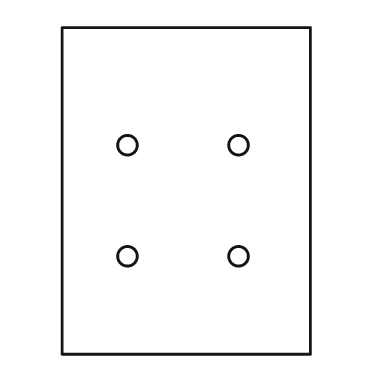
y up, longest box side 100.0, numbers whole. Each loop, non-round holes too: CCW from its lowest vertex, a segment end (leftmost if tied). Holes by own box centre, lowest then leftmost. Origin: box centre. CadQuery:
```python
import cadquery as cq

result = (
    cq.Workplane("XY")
    .moveTo(-38.0, -50.0)
    .lineTo(38.0, -50.0)
    .lineTo(38.0, 50.0)
    .lineTo(-38.0, 50.0)
    .close()
    .moveTo(-18.0, -20.0)
    .circle(3.0)
    .moveTo(16.0, -20.0)
    .circle(3.0)
    .moveTo(-18.0, 14.0)
    .circle(3.0)
    .moveTo(16.0, 14.0)
    .circle(3.0)
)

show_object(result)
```